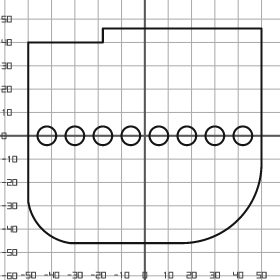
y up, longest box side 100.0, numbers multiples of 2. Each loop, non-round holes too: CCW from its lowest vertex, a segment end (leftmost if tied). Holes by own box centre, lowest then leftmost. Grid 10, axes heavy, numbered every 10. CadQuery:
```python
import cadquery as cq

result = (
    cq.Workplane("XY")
    .moveTo(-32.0, -46.0)
    .lineTo(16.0, -46.0)
    .threePointArc((40.0, -36.0), (50.0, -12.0))
    .lineTo(50.0, 46.0)
    .lineTo(-18.0, 46.0)
    .lineTo(-18.0, 40.0)
    .lineTo(-50.0, 40.0)
    .lineTo(-50.0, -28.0)
    .threePointArc((-44.0, -40.0), (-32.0, -46.0))
    .close()
    .moveTo(-42.0, 0.0)
    .circle(4.0)
    .moveTo(-30.0, 0.0)
    .circle(4.0)
    .moveTo(-18.0, 0.0)
    .circle(4.0)
    .moveTo(-6.0, 0.0)
    .circle(4.0)
    .moveTo(6.0, 0.0)
    .circle(4.0)
    .moveTo(18.0, 0.0)
    .circle(4.0)
    .moveTo(30.0, 0.0)
    .circle(4.0)
    .moveTo(42.0, 0.0)
    .circle(4.0)
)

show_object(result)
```